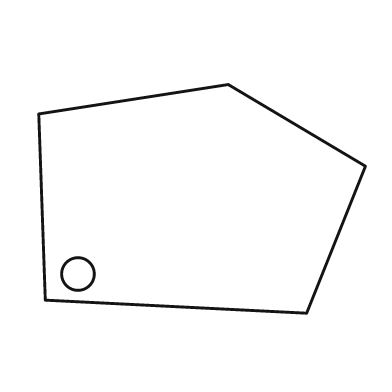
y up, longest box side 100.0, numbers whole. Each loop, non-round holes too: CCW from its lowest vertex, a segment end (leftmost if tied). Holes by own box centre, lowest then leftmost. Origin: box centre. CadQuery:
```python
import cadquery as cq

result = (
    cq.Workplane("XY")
    .moveTo(32.0, -35.0)
    .lineTo(50.0, 10.0)
    .lineTo(8.0, 35.0)
    .lineTo(-50.0, 26.0)
    .lineTo(-48.0, -31.0)
    .close()
    .moveTo(-38.0, -23.0)
    .circle(5.0)
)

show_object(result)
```